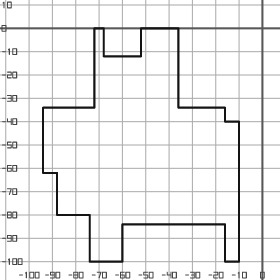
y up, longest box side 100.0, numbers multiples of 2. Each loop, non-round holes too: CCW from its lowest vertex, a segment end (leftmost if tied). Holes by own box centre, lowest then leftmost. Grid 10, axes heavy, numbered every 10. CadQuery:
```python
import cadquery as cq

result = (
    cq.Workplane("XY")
    .moveTo(-74.0, -100.0)
    .lineTo(-60.0, -100.0)
    .lineTo(-60.0, -84.0)
    .lineTo(-16.0, -84.0)
    .lineTo(-16.0, -100.0)
    .lineTo(-10.0, -100.0)
    .lineTo(-10.0, -40.0)
    .lineTo(-16.0, -40.0)
    .lineTo(-16.0, -34.0)
    .lineTo(-36.0, -34.0)
    .lineTo(-36.0, 0.0)
    .lineTo(-52.0, 0.0)
    .lineTo(-52.0, -12.0)
    .lineTo(-68.0, -12.0)
    .lineTo(-68.0, 0.0)
    .lineTo(-72.0, 0.0)
    .lineTo(-72.0, -34.0)
    .lineTo(-94.0, -34.0)
    .lineTo(-94.0, -62.0)
    .lineTo(-88.0, -62.0)
    .lineTo(-88.0, -80.0)
    .lineTo(-74.0, -80.0)
    .close()
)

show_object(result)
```